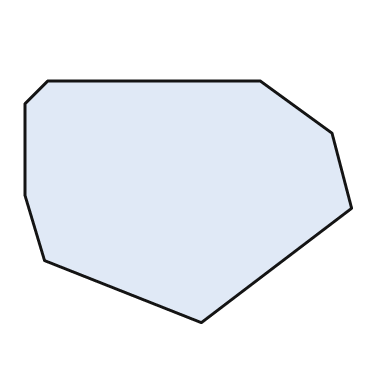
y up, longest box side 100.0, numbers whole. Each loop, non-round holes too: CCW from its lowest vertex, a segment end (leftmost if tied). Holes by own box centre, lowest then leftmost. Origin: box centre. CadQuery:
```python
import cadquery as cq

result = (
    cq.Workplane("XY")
    .moveTo(4.0, -37.0)
    .lineTo(50.0, -2.0)
    .lineTo(44.0, 21.0)
    .lineTo(22.0, 37.0)
    .lineTo(-43.0, 37.0)
    .lineTo(-50.0, 30.0)
    .lineTo(-50.0, 2.0)
    .lineTo(-44.0, -18.0)
    .close()
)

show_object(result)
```